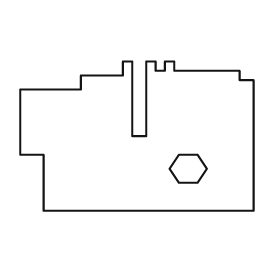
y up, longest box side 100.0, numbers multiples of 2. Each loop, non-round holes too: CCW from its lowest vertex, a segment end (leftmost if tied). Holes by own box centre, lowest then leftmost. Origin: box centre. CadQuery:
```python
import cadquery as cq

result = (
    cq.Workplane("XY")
    .moveTo(-40.0, -32.0)
    .lineTo(50.0, -32.0)
    .lineTo(50.0, 24.0)
    .lineTo(44.0, 24.0)
    .lineTo(44.0, 28.0)
    .lineTo(16.0, 28.0)
    .lineTo(16.0, 32.0)
    .lineTo(12.0, 32.0)
    .lineTo(12.0, 28.0)
    .lineTo(8.0, 28.0)
    .lineTo(8.0, 32.0)
    .lineTo(4.0, 32.0)
    .lineTo(4.0, 0.0)
    .lineTo(-2.0, 0.0)
    .lineTo(-2.0, 32.0)
    .lineTo(-6.0, 32.0)
    .lineTo(-6.0, 26.0)
    .lineTo(-24.0, 26.0)
    .lineTo(-24.0, 20.0)
    .lineTo(-50.0, 20.0)
    .lineTo(-50.0, -8.0)
    .lineTo(-40.0, -8.0)
    .close()
    .moveTo(18.0, -20.0)
    .lineTo(26.0, -20.0)
    .lineTo(30.0, -14.0)
    .lineTo(26.0, -8.0)
    .lineTo(18.0, -8.0)
    .lineTo(14.0, -14.0)
    .close()
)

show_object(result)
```